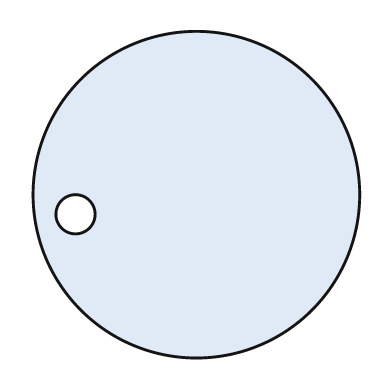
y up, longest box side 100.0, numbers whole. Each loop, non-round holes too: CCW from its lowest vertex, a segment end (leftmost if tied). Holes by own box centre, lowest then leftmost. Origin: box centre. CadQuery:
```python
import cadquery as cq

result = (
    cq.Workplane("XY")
    .moveTo(0.0, 0.0)
    .circle(50.0)
    .moveTo(-37.0, -6.0)
    .circle(6.0)
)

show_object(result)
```